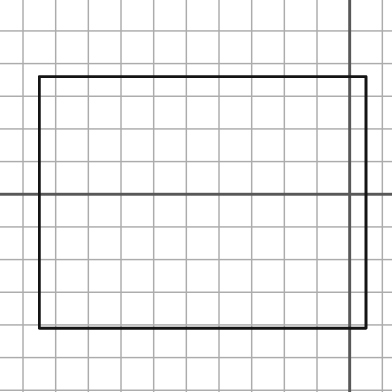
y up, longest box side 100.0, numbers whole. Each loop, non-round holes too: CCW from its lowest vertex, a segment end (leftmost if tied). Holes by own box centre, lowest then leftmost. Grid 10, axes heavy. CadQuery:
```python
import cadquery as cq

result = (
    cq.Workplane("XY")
    .moveTo(-95.0, -41.0)
    .lineTo(5.0, -41.0)
    .lineTo(5.0, 36.0)
    .lineTo(-95.0, 36.0)
    .close()
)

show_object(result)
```